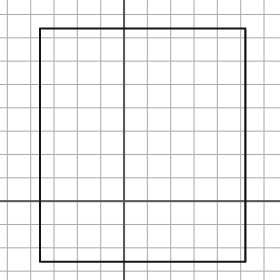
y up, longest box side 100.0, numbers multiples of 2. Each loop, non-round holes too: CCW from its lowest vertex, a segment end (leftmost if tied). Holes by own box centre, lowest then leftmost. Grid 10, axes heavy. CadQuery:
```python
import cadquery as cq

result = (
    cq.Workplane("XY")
    .moveTo(-36.0, -26.0)
    .lineTo(52.0, -26.0)
    .lineTo(52.0, 74.0)
    .lineTo(-36.0, 74.0)
    .close()
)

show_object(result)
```